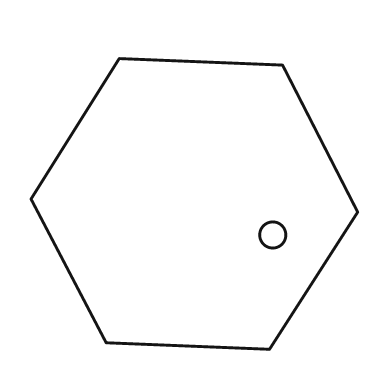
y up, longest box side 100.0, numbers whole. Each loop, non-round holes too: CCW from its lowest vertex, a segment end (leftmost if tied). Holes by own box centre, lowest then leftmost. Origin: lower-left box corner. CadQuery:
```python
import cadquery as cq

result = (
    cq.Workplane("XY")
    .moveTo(73.0, 0.0)
    .lineTo(100.0, 42.0)
    .lineTo(77.0, 87.0)
    .lineTo(27.0, 89.0)
    .lineTo(0.0, 46.0)
    .lineTo(23.0, 2.0)
    .close()
    .moveTo(74.0, 35.0)
    .circle(4.0)
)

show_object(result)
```